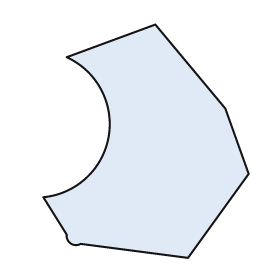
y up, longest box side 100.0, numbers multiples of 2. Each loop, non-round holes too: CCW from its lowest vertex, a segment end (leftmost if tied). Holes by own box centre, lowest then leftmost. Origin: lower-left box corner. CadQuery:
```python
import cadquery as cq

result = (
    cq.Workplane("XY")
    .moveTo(62.0, 0.0)
    .lineTo(88.0, 36.0)
    .lineTo(78.0, 64.0)
    .lineTo(48.0, 100.0)
    .lineTo(10.0, 86.0)
    .threePointArc((28.0, 52.0), (0.0, 26.0))
    .lineTo(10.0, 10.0)
    .threePointArc((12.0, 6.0), (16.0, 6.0))
    .close()
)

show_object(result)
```